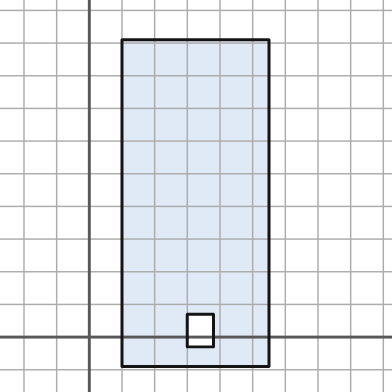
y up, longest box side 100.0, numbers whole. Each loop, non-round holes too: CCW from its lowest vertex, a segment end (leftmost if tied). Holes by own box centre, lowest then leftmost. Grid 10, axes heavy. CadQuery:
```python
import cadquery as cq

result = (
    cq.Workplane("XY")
    .moveTo(10.0, -9.0)
    .lineTo(55.0, -9.0)
    .lineTo(55.0, 91.0)
    .lineTo(10.0, 91.0)
    .close()
    .moveTo(30.0, -3.0)
    .lineTo(38.0, -3.0)
    .lineTo(38.0, 7.0)
    .lineTo(30.0, 7.0)
    .close()
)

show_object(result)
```